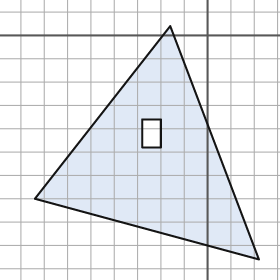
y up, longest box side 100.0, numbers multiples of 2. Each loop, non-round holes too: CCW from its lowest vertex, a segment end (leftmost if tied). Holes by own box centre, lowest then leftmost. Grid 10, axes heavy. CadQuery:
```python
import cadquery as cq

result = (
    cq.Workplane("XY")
    .moveTo(22.0, -96.0)
    .lineTo(-16.0, 4.0)
    .lineTo(-74.0, -70.0)
    .close()
    .moveTo(-28.0, -48.0)
    .lineTo(-20.0, -48.0)
    .lineTo(-20.0, -36.0)
    .lineTo(-28.0, -36.0)
    .close()
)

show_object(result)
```